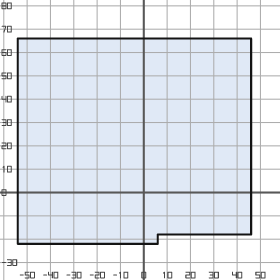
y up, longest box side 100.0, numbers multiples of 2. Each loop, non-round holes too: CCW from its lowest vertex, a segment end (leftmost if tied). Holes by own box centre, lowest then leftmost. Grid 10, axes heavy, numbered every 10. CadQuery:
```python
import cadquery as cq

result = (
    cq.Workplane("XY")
    .moveTo(-54.0, -22.0)
    .lineTo(6.0, -22.0)
    .lineTo(6.0, -18.0)
    .lineTo(46.0, -18.0)
    .lineTo(46.0, 66.0)
    .lineTo(-54.0, 66.0)
    .close()
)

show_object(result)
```